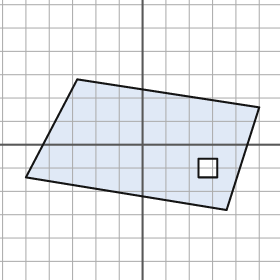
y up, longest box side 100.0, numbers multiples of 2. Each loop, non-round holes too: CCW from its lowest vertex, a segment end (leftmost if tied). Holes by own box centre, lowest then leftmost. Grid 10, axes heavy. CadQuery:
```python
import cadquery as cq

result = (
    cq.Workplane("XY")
    .moveTo(36.0, -28.0)
    .lineTo(50.0, 16.0)
    .lineTo(-28.0, 28.0)
    .lineTo(-50.0, -14.0)
    .close()
    .moveTo(24.0, -14.0)
    .lineTo(32.0, -14.0)
    .lineTo(32.0, -6.0)
    .lineTo(24.0, -6.0)
    .close()
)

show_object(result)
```